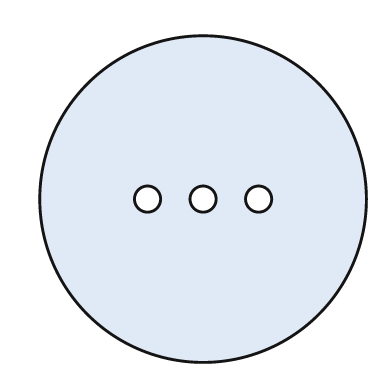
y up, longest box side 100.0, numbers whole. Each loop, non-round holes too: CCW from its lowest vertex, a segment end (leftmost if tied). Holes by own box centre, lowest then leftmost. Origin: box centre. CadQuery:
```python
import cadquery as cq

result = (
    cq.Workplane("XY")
    .moveTo(0.0, 0.0)
    .circle(50.0)
    .moveTo(-17.0, 0.0)
    .circle(4.0)
    .moveTo(0.0, 0.0)
    .circle(4.0)
    .moveTo(17.0, 0.0)
    .circle(4.0)
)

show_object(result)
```